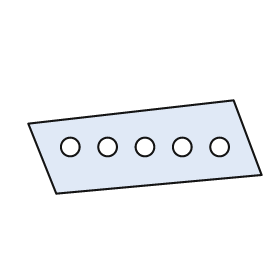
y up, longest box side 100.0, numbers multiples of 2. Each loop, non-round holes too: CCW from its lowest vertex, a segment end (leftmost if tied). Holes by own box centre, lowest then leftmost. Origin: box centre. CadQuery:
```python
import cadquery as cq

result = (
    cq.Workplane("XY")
    .moveTo(-38.0, -20.0)
    .lineTo(50.0, -12.0)
    .lineTo(38.0, 20.0)
    .lineTo(-50.0, 10.0)
    .close()
    .moveTo(-32.0, 0.0)
    .circle(4.0)
    .moveTo(-16.0, 0.0)
    .circle(4.0)
    .moveTo(0.0, 0.0)
    .circle(4.0)
    .moveTo(16.0, 0.0)
    .circle(4.0)
    .moveTo(32.0, 0.0)
    .circle(4.0)
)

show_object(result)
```